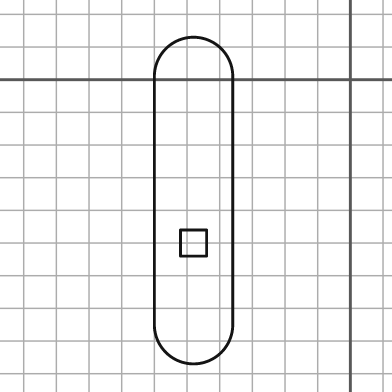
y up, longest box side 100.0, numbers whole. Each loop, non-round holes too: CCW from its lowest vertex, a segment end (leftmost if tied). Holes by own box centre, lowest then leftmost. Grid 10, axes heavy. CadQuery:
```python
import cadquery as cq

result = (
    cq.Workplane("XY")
    .moveTo(-60.0, -75.0)
    .threePointArc((-48.0, -87.0), (-36.0, -75.0))
    .lineTo(-36.0, 1.0)
    .threePointArc((-48.0, 13.0), (-60.0, 1.0))
    .close()
    .moveTo(-52.0, -54.0)
    .lineTo(-44.0, -54.0)
    .lineTo(-44.0, -46.0)
    .lineTo(-52.0, -46.0)
    .close()
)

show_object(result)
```